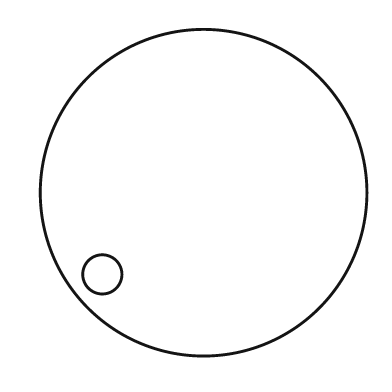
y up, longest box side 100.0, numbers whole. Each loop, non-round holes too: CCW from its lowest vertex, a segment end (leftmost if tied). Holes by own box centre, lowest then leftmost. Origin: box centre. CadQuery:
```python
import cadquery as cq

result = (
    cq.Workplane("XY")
    .moveTo(0.0, 0.0)
    .circle(50.0)
    .moveTo(-31.0, -25.0)
    .circle(6.0)
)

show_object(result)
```